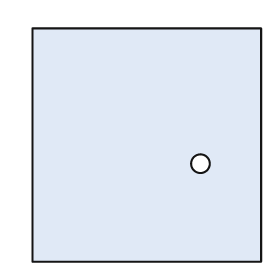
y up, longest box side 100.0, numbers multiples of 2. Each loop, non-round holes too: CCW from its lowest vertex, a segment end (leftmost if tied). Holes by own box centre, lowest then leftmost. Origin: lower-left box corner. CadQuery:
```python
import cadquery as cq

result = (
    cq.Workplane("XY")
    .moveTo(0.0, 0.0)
    .lineTo(98.0, 0.0)
    .lineTo(98.0, 100.0)
    .lineTo(0.0, 100.0)
    .close()
    .moveTo(72.0, 42.0)
    .circle(4.0)
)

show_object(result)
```